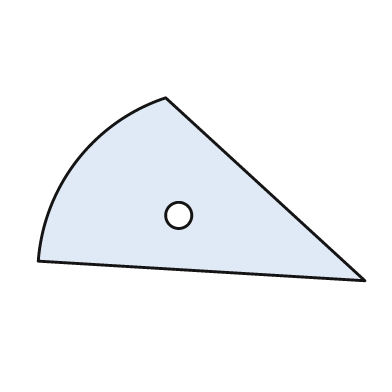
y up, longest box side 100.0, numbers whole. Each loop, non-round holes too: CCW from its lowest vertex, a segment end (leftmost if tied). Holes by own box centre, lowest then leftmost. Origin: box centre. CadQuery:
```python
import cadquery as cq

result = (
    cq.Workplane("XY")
    .moveTo(50.0, -28.0)
    .lineTo(-11.0, 28.0)
    .threePointArc((-38.0, 9.0), (-50.0, -22.0))
    .close()
    .moveTo(-7.0, -8.0)
    .circle(4.0)
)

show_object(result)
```